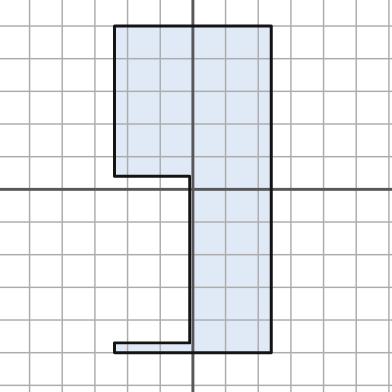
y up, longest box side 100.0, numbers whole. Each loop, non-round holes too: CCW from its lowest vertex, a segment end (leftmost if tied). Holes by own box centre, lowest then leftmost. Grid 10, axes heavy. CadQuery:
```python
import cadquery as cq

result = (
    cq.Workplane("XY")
    .moveTo(-24.0, -50.0)
    .lineTo(24.0, -50.0)
    .lineTo(24.0, 50.0)
    .lineTo(-24.0, 50.0)
    .lineTo(-24.0, 4.0)
    .lineTo(-1.0, 4.0)
    .lineTo(-1.0, -47.0)
    .lineTo(-24.0, -47.0)
    .close()
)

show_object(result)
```